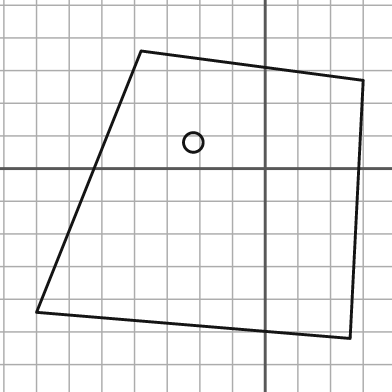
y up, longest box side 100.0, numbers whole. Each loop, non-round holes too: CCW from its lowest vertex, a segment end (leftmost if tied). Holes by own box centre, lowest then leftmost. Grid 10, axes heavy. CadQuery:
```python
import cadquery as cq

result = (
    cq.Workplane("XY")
    .moveTo(26.0, -52.0)
    .lineTo(30.0, 27.0)
    .lineTo(-38.0, 36.0)
    .lineTo(-70.0, -44.0)
    .close()
    .moveTo(-22.0, 8.0)
    .circle(3.0)
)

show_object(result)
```